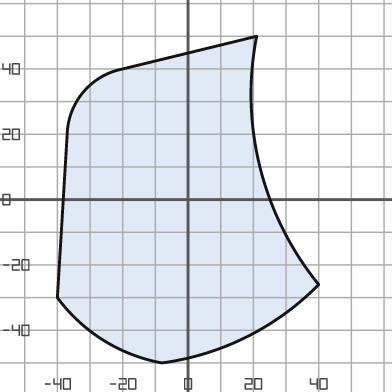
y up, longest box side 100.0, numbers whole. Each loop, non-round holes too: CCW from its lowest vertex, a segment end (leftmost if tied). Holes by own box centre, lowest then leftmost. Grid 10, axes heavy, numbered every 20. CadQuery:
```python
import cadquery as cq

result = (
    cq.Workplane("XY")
    .moveTo(-8.0, -50.0)
    .threePointArc((18.0, -42.0), (40.0, -26.0))
    .threePointArc((22.0, 10.0), (21.0, 50.0))
    .lineTo(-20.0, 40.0)
    .threePointArc((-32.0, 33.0), (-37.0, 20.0))
    .lineTo(-40.0, -30.0)
    .threePointArc((-26.0, -43.0), (-8.0, -50.0))
    .close()
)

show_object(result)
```